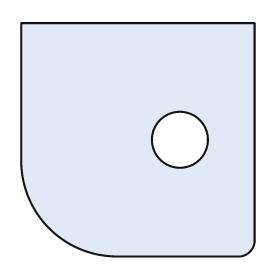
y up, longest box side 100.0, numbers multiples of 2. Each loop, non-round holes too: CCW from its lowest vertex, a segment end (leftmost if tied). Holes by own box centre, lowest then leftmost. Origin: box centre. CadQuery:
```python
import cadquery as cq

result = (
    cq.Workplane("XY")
    .moveTo(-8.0, -50.0)
    .lineTo(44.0, -50.0)
    .threePointArc((48.0, -48.0), (50.0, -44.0))
    .lineTo(50.0, 50.0)
    .lineTo(-50.0, 50.0)
    .lineTo(-50.0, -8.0)
    .threePointArc((-38.0, -38.0), (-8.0, -50.0))
    .close()
    .moveTo(18.0, 0.0)
    .circle(12.0)
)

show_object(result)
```